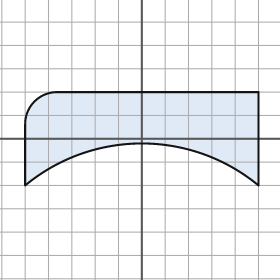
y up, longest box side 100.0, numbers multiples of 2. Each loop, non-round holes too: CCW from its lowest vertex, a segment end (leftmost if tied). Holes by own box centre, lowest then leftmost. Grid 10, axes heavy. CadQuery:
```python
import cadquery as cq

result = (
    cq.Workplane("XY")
    .moveTo(-50.0, -20.0)
    .threePointArc((0.0, -2.0), (50.0, -20.0))
    .lineTo(50.0, 20.0)
    .lineTo(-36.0, 20.0)
    .threePointArc((-46.0, 16.0), (-50.0, 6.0))
    .close()
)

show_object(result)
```